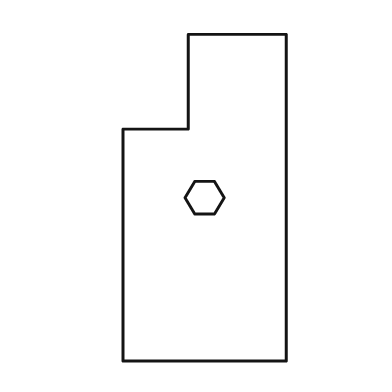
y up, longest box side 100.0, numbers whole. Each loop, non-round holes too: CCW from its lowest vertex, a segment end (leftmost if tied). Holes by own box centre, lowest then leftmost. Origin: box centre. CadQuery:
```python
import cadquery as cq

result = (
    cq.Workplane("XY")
    .moveTo(-25.0, -50.0)
    .lineTo(25.0, -50.0)
    .lineTo(25.0, 50.0)
    .lineTo(-5.0, 50.0)
    .lineTo(-5.0, 21.0)
    .lineTo(-25.0, 21.0)
    .close()
    .moveTo(-3.0, -5.0)
    .lineTo(3.0, -5.0)
    .lineTo(6.0, 0.0)
    .lineTo(3.0, 5.0)
    .lineTo(-3.0, 5.0)
    .lineTo(-6.0, 0.0)
    .close()
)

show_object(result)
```